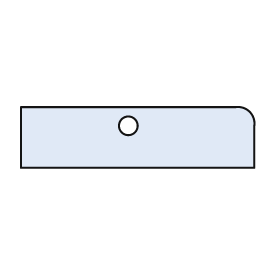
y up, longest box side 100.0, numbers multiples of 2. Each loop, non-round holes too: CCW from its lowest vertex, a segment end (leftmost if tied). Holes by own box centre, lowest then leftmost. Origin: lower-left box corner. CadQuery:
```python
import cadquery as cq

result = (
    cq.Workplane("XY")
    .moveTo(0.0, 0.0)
    .lineTo(100.0, 0.0)
    .lineTo(100.0, 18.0)
    .threePointArc((98.0, 24.0), (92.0, 26.0))
    .lineTo(0.0, 26.0)
    .close()
    .moveTo(46.0, 18.0)
    .circle(4.0)
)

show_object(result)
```